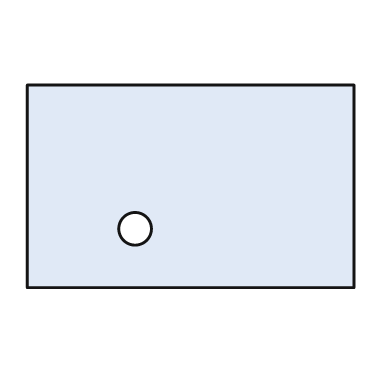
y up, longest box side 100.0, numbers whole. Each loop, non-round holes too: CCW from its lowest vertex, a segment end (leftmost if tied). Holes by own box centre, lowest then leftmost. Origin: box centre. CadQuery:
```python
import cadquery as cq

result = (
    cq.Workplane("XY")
    .moveTo(-50.0, -31.0)
    .lineTo(50.0, -31.0)
    .lineTo(50.0, 31.0)
    .lineTo(-50.0, 31.0)
    .close()
    .moveTo(-17.0, -13.0)
    .circle(5.0)
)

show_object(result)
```